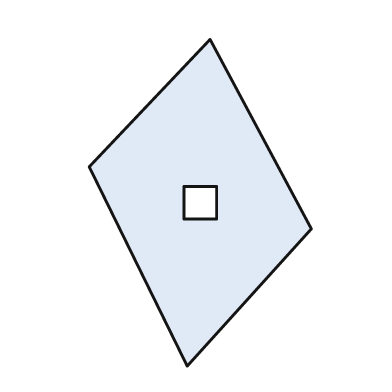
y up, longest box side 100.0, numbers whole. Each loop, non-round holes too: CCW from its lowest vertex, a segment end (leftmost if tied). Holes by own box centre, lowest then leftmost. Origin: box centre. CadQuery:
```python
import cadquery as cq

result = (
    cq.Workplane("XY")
    .moveTo(-4.0, -50.0)
    .lineTo(34.0, -8.0)
    .lineTo(3.0, 50.0)
    .lineTo(-34.0, 11.0)
    .close()
    .moveTo(-5.0, -5.0)
    .lineTo(5.0, -5.0)
    .lineTo(5.0, 5.0)
    .lineTo(-5.0, 5.0)
    .close()
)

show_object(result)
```